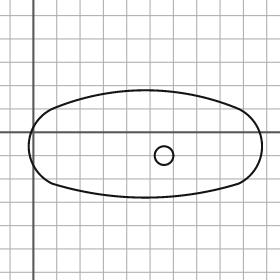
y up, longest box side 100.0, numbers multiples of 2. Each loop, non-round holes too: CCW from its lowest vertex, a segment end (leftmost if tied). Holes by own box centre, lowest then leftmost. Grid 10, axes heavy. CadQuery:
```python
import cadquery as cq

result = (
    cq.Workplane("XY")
    .moveTo(8.0, -22.0)
    .threePointArc((48.0, -28.0), (88.0, -22.0))
    .threePointArc((98.0, -6.0), (88.0, 10.0))
    .threePointArc((48.0, 18.0), (8.0, 10.0))
    .threePointArc((-2.0, -6.0), (8.0, -22.0))
    .close()
    .moveTo(56.0, -10.0)
    .circle(4.0)
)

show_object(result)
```